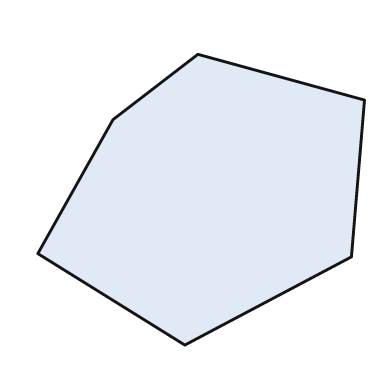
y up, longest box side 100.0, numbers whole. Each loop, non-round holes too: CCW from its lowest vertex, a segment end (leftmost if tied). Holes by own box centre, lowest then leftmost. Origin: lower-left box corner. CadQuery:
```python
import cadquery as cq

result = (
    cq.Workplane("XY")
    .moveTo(45.0, 0.0)
    .lineTo(96.0, 27.0)
    .lineTo(100.0, 75.0)
    .lineTo(49.0, 89.0)
    .lineTo(23.0, 69.0)
    .lineTo(0.0, 28.0)
    .close()
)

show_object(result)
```